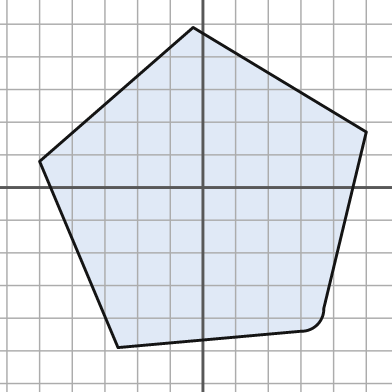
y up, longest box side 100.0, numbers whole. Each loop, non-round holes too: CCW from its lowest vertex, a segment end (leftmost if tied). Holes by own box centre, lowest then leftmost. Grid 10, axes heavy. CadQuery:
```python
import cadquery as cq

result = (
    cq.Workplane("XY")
    .moveTo(-26.0, -49.0)
    .lineTo(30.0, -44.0)
    .threePointArc((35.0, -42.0), (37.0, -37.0))
    .lineTo(50.0, 17.0)
    .lineTo(-3.0, 49.0)
    .lineTo(-50.0, 8.0)
    .close()
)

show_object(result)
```